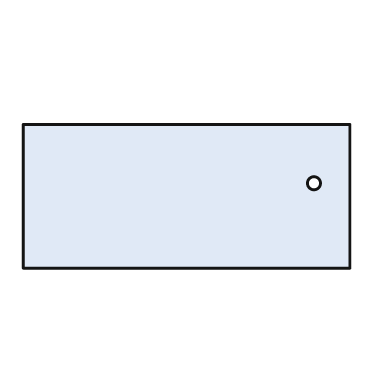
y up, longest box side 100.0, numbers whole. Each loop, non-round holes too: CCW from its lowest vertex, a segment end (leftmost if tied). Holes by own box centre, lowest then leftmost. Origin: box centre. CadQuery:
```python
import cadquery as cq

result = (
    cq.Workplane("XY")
    .moveTo(-50.0, -22.0)
    .lineTo(50.0, -22.0)
    .lineTo(50.0, 22.0)
    .lineTo(-50.0, 22.0)
    .close()
    .moveTo(39.0, 4.0)
    .circle(2.0)
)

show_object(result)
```